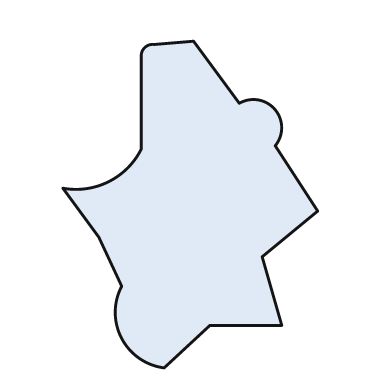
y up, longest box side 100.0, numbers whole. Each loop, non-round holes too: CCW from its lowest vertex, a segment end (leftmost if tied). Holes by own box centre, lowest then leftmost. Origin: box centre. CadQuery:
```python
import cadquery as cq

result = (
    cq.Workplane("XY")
    .moveTo(-8.0, -50.0)
    .lineTo(6.0, -37.0)
    .lineTo(28.0, -37.0)
    .lineTo(22.0, -16.0)
    .lineTo(39.0, -2.0)
    .lineTo(26.0, 18.0)
    .threePointArc((26.0, 29.0), (15.0, 31.0))
    .lineTo(1.0, 50.0)
    .lineTo(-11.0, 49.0)
    .threePointArc((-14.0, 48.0), (-15.0, 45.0))
    .lineTo(-15.0, 17.0)
    .threePointArc((-25.0, 7.0), (-39.0, 5.0))
    .lineTo(-28.0, -10.0)
    .lineTo(-21.0, -25.0)
    .threePointArc((-21.0, -41.0), (-8.0, -50.0))
    .close()
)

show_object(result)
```